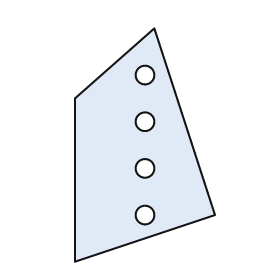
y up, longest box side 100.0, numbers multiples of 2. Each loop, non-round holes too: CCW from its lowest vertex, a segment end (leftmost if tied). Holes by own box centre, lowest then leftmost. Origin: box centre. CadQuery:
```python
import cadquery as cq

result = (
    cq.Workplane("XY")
    .moveTo(-30.0, -50.0)
    .lineTo(30.0, -30.0)
    .lineTo(4.0, 50.0)
    .lineTo(-30.0, 20.0)
    .close()
    .moveTo(0.0, -30.0)
    .circle(4.0)
    .moveTo(0.0, -10.0)
    .circle(4.0)
    .moveTo(0.0, 10.0)
    .circle(4.0)
    .moveTo(0.0, 30.0)
    .circle(4.0)
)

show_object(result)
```